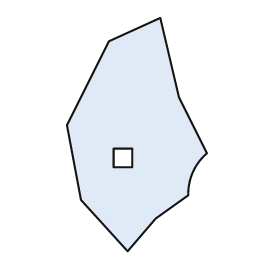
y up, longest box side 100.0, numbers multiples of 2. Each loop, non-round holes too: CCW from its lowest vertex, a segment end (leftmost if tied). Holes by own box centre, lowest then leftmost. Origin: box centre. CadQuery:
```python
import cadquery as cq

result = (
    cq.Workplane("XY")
    .moveTo(-4.0, -50.0)
    .lineTo(8.0, -36.0)
    .lineTo(22.0, -26.0)
    .threePointArc((24.0, -16.0), (30.0, -8.0))
    .lineTo(18.0, 16.0)
    .lineTo(10.0, 50.0)
    .lineTo(-12.0, 40.0)
    .lineTo(-30.0, 4.0)
    .lineTo(-24.0, -28.0)
    .close()
    .moveTo(-10.0, -14.0)
    .lineTo(-2.0, -14.0)
    .lineTo(-2.0, -6.0)
    .lineTo(-10.0, -6.0)
    .close()
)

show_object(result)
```